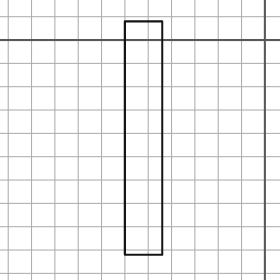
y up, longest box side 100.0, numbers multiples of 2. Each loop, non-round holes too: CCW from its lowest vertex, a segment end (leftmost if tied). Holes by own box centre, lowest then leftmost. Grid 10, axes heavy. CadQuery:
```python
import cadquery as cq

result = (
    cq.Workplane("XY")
    .moveTo(-60.0, -92.0)
    .lineTo(-44.0, -92.0)
    .lineTo(-44.0, 8.0)
    .lineTo(-60.0, 8.0)
    .close()
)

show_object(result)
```